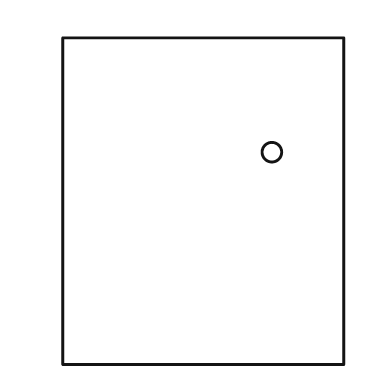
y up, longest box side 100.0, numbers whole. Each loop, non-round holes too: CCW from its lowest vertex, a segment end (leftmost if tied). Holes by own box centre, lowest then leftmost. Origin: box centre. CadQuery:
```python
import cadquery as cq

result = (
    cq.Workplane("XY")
    .moveTo(-43.0, -50.0)
    .lineTo(43.0, -50.0)
    .lineTo(43.0, 50.0)
    .lineTo(-43.0, 50.0)
    .close()
    .moveTo(21.0, 15.0)
    .circle(3.0)
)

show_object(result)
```